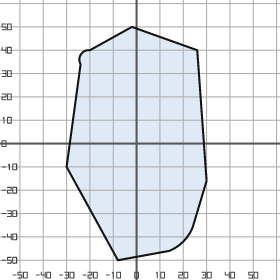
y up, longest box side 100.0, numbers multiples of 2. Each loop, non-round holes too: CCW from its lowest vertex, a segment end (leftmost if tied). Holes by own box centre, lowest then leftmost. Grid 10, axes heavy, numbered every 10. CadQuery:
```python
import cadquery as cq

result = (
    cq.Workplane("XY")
    .moveTo(-8.0, -50.0)
    .lineTo(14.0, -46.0)
    .threePointArc((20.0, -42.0), (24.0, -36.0))
    .lineTo(30.0, -16.0)
    .lineTo(26.0, 40.0)
    .lineTo(-2.0, 50.0)
    .lineTo(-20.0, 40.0)
    .threePointArc((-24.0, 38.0), (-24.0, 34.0))
    .lineTo(-30.0, -10.0)
    .close()
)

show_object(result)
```